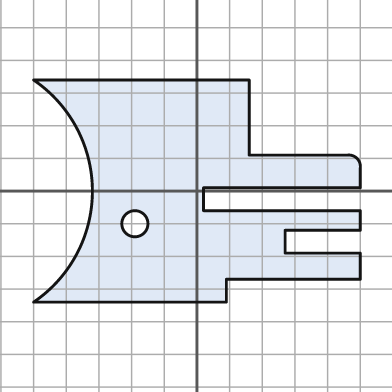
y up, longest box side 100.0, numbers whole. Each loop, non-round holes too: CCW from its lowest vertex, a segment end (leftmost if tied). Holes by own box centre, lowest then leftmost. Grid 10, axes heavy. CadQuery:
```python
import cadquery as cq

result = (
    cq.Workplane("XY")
    .moveTo(-50.0, -34.0)
    .lineTo(9.0, -34.0)
    .lineTo(9.0, -27.0)
    .lineTo(50.0, -27.0)
    .lineTo(50.0, -19.0)
    .lineTo(27.0, -19.0)
    .lineTo(27.0, -12.0)
    .lineTo(50.0, -12.0)
    .lineTo(50.0, -6.0)
    .lineTo(2.0, -6.0)
    .lineTo(2.0, 1.0)
    .lineTo(50.0, 1.0)
    .lineTo(50.0, 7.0)
    .threePointArc((49.0, 10.0), (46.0, 11.0))
    .lineTo(16.0, 11.0)
    .lineTo(16.0, 34.0)
    .lineTo(-50.0, 34.0)
    .threePointArc((-32.0, 0.0), (-50.0, -34.0))
    .close()
    .moveTo(-19.0, -10.0)
    .circle(4.0)
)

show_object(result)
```